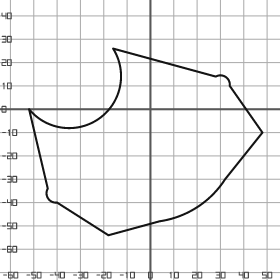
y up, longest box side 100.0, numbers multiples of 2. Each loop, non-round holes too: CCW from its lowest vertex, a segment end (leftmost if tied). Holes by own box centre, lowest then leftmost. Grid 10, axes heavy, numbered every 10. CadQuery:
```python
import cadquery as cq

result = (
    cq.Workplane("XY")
    .moveTo(-18.0, -54.0)
    .lineTo(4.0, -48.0)
    .threePointArc((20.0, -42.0), (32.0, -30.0))
    .lineTo(48.0, -10.0)
    .lineTo(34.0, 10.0)
    .threePointArc((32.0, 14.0), (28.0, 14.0))
    .lineTo(-16.0, 26.0)
    .threePointArc((-22.0, -4.0), (-52.0, 0.0))
    .lineTo(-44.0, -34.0)
    .threePointArc((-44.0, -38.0), (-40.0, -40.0))
    .close()
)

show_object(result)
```